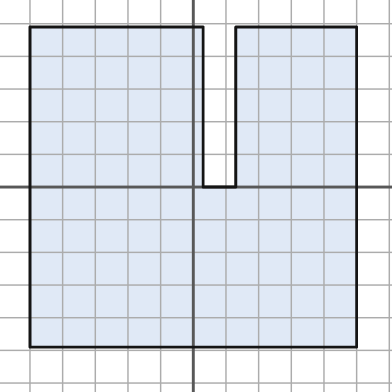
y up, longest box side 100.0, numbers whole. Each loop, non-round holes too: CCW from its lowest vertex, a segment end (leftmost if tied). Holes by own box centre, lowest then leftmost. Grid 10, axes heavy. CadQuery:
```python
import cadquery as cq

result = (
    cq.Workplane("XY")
    .moveTo(-50.0, -49.0)
    .lineTo(50.0, -49.0)
    .lineTo(50.0, 49.0)
    .lineTo(13.0, 49.0)
    .lineTo(13.0, 0.0)
    .lineTo(3.0, 0.0)
    .lineTo(3.0, 49.0)
    .lineTo(-50.0, 49.0)
    .close()
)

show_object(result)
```